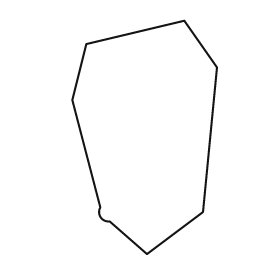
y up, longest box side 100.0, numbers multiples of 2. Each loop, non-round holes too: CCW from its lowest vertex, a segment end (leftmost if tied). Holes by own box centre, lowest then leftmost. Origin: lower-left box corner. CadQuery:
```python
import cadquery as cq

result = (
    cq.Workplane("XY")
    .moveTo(32.0, 0.0)
    .lineTo(56.0, 18.0)
    .lineTo(62.0, 80.0)
    .lineTo(48.0, 100.0)
    .lineTo(6.0, 90.0)
    .lineTo(0.0, 66.0)
    .lineTo(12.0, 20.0)
    .threePointArc((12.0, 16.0), (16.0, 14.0))
    .close()
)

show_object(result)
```